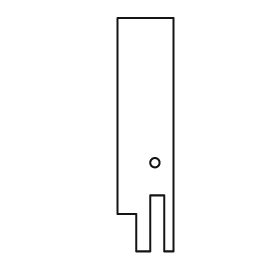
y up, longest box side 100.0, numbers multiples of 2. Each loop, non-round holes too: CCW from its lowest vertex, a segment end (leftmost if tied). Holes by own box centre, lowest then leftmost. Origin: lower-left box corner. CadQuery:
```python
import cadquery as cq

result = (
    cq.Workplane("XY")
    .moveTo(8.0, 0.0)
    .lineTo(14.0, 0.0)
    .lineTo(14.0, 24.0)
    .lineTo(20.0, 24.0)
    .lineTo(20.0, 0.0)
    .lineTo(24.0, 0.0)
    .lineTo(24.0, 100.0)
    .lineTo(0.0, 100.0)
    .lineTo(0.0, 16.0)
    .lineTo(8.0, 16.0)
    .close()
    .moveTo(16.0, 38.0)
    .circle(2.0)
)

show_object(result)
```